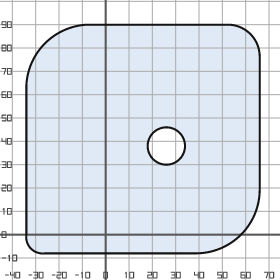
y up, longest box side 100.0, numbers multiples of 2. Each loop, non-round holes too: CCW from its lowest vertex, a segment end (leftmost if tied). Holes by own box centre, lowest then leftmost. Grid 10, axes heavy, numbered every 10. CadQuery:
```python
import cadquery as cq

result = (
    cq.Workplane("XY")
    .moveTo(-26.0, -8.0)
    .lineTo(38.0, -8.0)
    .threePointArc((58.0, 0.0), (66.0, 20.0))
    .lineTo(66.0, 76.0)
    .threePointArc((62.0, 86.0), (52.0, 90.0))
    .lineTo(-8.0, 90.0)
    .threePointArc((-26.0, 82.0), (-34.0, 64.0))
    .lineTo(-34.0, 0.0)
    .threePointArc((-32.0, -6.0), (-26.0, -8.0))
    .close()
    .moveTo(26.0, 38.0)
    .circle(8.0)
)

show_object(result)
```